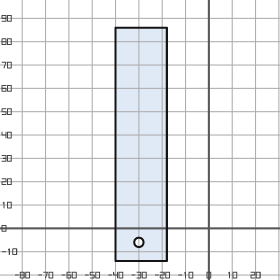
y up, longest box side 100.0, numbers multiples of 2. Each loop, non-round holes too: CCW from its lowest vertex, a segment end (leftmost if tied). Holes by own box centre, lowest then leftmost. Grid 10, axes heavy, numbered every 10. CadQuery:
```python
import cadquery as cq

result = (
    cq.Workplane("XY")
    .moveTo(-40.0, -14.0)
    .lineTo(-18.0, -14.0)
    .lineTo(-18.0, 86.0)
    .lineTo(-40.0, 86.0)
    .close()
    .moveTo(-30.0, -6.0)
    .circle(2.0)
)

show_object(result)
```